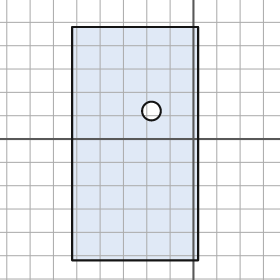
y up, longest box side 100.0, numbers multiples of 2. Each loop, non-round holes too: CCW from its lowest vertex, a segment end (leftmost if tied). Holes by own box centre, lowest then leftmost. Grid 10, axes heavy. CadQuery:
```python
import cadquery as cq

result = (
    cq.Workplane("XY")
    .moveTo(-52.0, -52.0)
    .lineTo(2.0, -52.0)
    .lineTo(2.0, 48.0)
    .lineTo(-52.0, 48.0)
    .close()
    .moveTo(-18.0, 12.0)
    .circle(4.0)
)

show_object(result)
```